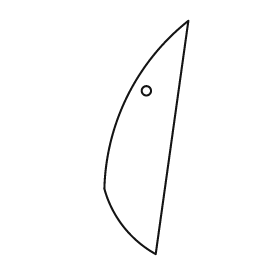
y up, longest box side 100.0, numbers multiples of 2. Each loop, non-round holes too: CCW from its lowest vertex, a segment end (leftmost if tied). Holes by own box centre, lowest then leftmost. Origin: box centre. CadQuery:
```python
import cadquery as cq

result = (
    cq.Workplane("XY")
    .moveTo(4.0, -50.0)
    .lineTo(18.0, 50.0)
    .threePointArc((-8.0, 18.0), (-18.0, -22.0))
    .threePointArc((-10.0, -38.0), (4.0, -50.0))
    .close()
    .moveTo(0.0, 20.0)
    .circle(2.0)
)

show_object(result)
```